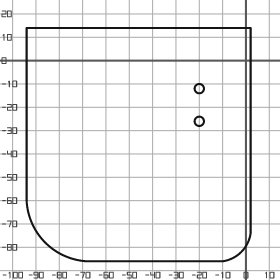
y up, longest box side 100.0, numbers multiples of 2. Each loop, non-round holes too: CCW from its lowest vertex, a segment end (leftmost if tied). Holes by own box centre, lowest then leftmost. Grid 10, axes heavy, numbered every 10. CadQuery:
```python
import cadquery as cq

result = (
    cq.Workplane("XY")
    .moveTo(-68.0, -86.0)
    .lineTo(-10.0, -86.0)
    .threePointArc((-2.0, -82.0), (2.0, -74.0))
    .lineTo(2.0, 14.0)
    .lineTo(-94.0, 14.0)
    .lineTo(-94.0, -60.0)
    .threePointArc((-86.0, -78.0), (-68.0, -86.0))
    .close()
    .moveTo(-20.0, -26.0)
    .circle(2.0)
    .moveTo(-20.0, -12.0)
    .circle(2.0)
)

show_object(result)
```